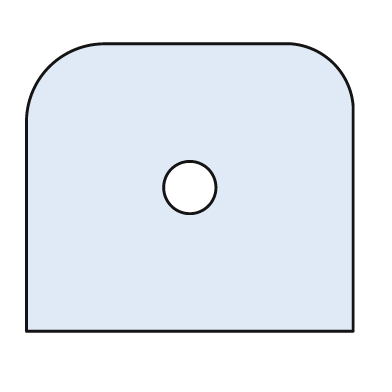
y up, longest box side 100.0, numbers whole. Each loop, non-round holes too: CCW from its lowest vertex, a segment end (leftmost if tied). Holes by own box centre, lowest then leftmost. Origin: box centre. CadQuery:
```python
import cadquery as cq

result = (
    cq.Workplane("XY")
    .moveTo(-50.0, -44.0)
    .lineTo(50.0, -44.0)
    .lineTo(50.0, 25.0)
    .threePointArc((44.0, 38.0), (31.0, 44.0))
    .lineTo(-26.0, 44.0)
    .threePointArc((-43.0, 37.0), (-50.0, 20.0))
    .close()
    .moveTo(0.0, 0.0)
    .circle(8.0)
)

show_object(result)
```